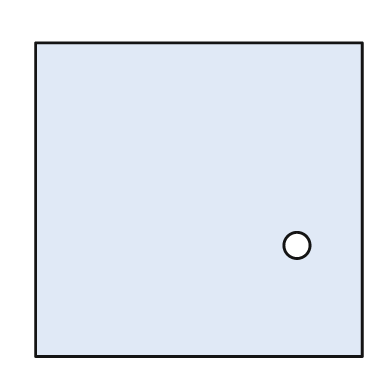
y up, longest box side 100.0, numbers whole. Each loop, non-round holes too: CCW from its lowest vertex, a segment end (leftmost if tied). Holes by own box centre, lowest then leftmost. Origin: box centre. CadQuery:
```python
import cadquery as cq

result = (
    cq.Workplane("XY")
    .moveTo(-50.0, -48.0)
    .lineTo(50.0, -48.0)
    .lineTo(50.0, 48.0)
    .lineTo(-50.0, 48.0)
    .close()
    .moveTo(30.0, -14.0)
    .circle(4.0)
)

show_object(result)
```